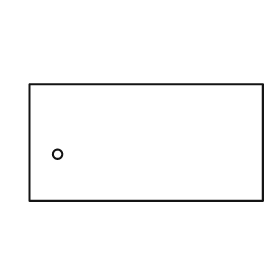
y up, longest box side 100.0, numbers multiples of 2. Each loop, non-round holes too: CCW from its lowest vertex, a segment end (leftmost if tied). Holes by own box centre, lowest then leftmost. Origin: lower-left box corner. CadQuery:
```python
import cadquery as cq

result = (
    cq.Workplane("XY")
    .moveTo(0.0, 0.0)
    .lineTo(100.0, 0.0)
    .lineTo(100.0, 50.0)
    .lineTo(0.0, 50.0)
    .close()
    .moveTo(12.0, 20.0)
    .circle(2.0)
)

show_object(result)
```